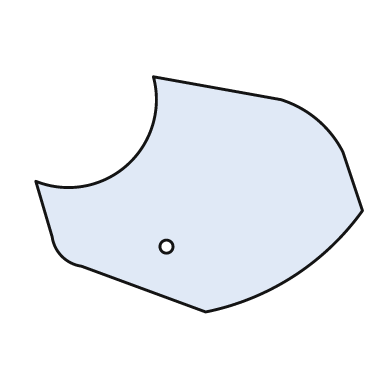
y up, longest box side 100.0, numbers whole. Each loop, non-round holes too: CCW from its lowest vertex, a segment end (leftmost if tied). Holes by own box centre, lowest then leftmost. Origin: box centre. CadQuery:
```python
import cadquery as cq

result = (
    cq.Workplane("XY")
    .moveTo(2.0, -36.0)
    .threePointArc((29.0, -25.0), (50.0, -5.0))
    .lineTo(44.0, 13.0)
    .threePointArc((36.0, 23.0), (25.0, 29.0))
    .lineTo(-14.0, 36.0)
    .threePointArc((-22.0, 9.0), (-50.0, 4.0))
    .lineTo(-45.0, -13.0)
    .threePointArc((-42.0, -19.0), (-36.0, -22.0))
    .close()
    .moveTo(-10.0, -16.0)
    .circle(2.0)
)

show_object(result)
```